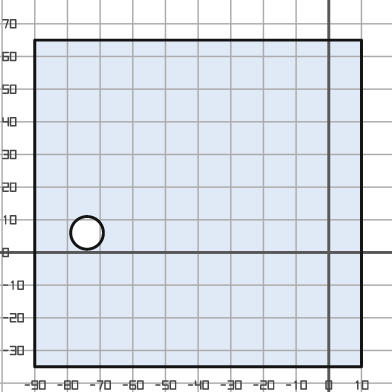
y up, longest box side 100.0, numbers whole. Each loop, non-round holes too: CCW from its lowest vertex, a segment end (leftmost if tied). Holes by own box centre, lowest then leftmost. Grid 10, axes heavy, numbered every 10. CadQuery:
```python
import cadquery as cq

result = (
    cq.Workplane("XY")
    .moveTo(-90.0, -35.0)
    .lineTo(10.0, -35.0)
    .lineTo(10.0, 65.0)
    .lineTo(-90.0, 65.0)
    .close()
    .moveTo(-74.0, 6.0)
    .circle(5.0)
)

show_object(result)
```